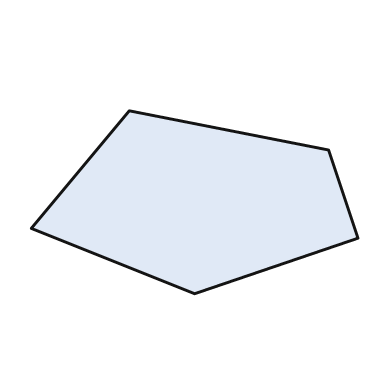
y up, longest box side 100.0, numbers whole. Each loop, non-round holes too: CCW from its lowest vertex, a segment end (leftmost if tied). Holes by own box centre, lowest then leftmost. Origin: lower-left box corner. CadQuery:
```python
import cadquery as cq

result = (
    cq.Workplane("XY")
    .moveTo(50.0, 0.0)
    .lineTo(100.0, 17.0)
    .lineTo(91.0, 44.0)
    .lineTo(30.0, 56.0)
    .lineTo(0.0, 20.0)
    .close()
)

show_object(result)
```